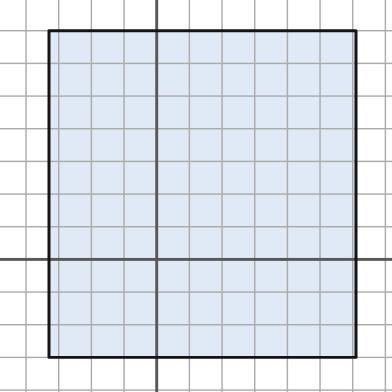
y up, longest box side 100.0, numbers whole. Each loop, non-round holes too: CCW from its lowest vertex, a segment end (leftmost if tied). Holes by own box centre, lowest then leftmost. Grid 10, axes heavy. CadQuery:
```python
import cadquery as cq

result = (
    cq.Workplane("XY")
    .moveTo(-33.0, -30.0)
    .lineTo(61.0, -30.0)
    .lineTo(61.0, 70.0)
    .lineTo(-33.0, 70.0)
    .close()
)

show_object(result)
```